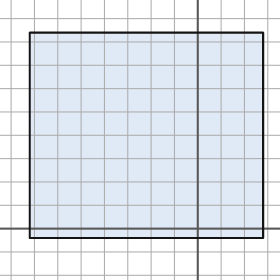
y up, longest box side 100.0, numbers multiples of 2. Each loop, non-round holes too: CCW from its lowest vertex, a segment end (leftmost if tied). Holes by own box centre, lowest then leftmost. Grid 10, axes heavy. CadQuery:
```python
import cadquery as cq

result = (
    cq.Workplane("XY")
    .moveTo(-72.0, -4.0)
    .lineTo(28.0, -4.0)
    .lineTo(28.0, 84.0)
    .lineTo(-72.0, 84.0)
    .close()
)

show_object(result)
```